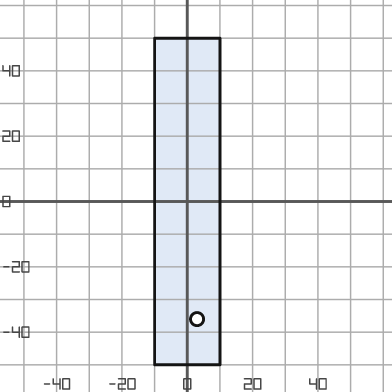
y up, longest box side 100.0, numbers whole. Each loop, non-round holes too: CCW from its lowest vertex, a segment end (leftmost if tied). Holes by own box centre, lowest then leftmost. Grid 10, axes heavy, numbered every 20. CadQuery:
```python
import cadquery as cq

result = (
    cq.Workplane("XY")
    .moveTo(-10.0, -50.0)
    .lineTo(10.0, -50.0)
    .lineTo(10.0, 50.0)
    .lineTo(-10.0, 50.0)
    .close()
    .moveTo(3.0, -36.0)
    .circle(2.0)
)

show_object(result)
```